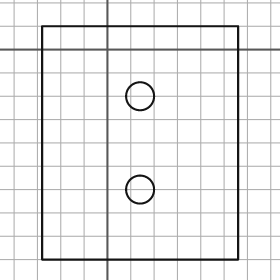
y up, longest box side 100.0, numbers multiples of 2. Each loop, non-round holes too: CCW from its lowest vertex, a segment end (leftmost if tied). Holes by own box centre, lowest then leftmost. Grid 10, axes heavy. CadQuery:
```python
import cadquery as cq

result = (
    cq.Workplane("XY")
    .moveTo(-28.0, -90.0)
    .lineTo(56.0, -90.0)
    .lineTo(56.0, 10.0)
    .lineTo(-28.0, 10.0)
    .close()
    .moveTo(14.0, -60.0)
    .circle(6.0)
    .moveTo(14.0, -20.0)
    .circle(6.0)
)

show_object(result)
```